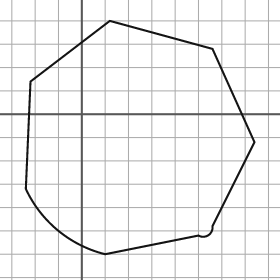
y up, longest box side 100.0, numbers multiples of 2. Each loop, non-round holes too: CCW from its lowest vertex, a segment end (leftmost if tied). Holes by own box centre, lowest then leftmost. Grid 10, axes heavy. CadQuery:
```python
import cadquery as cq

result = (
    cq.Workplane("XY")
    .moveTo(10.0, -60.0)
    .lineTo(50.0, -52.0)
    .threePointArc((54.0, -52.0), (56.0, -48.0))
    .lineTo(74.0, -12.0)
    .lineTo(56.0, 28.0)
    .lineTo(12.0, 40.0)
    .lineTo(-22.0, 14.0)
    .lineTo(-24.0, -32.0)
    .threePointArc((-10.0, -50.0), (10.0, -60.0))
    .close()
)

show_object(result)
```